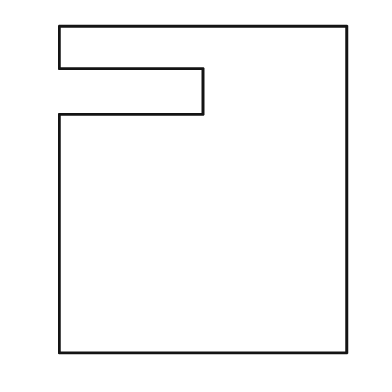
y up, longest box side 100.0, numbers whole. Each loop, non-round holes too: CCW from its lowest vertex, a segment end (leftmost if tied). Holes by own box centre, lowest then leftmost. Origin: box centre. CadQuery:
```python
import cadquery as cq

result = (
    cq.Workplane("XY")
    .moveTo(-44.0, -50.0)
    .lineTo(44.0, -50.0)
    .lineTo(44.0, 50.0)
    .lineTo(-44.0, 50.0)
    .lineTo(-44.0, 37.0)
    .lineTo(0.0, 37.0)
    .lineTo(0.0, 23.0)
    .lineTo(-44.0, 23.0)
    .close()
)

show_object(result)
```